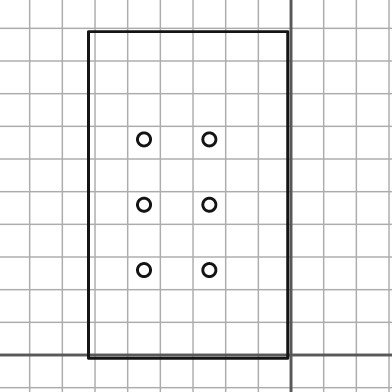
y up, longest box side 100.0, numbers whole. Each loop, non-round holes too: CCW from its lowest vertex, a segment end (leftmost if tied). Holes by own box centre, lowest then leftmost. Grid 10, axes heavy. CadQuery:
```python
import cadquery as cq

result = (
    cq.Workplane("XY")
    .moveTo(-62.0, -1.0)
    .lineTo(-1.0, -1.0)
    .lineTo(-1.0, 99.0)
    .lineTo(-62.0, 99.0)
    .close()
    .moveTo(-45.0, 26.0)
    .circle(2.0)
    .moveTo(-25.0, 26.0)
    .circle(2.0)
    .moveTo(-45.0, 46.0)
    .circle(2.0)
    .moveTo(-25.0, 46.0)
    .circle(2.0)
    .moveTo(-45.0, 66.0)
    .circle(2.0)
    .moveTo(-25.0, 66.0)
    .circle(2.0)
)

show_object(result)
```